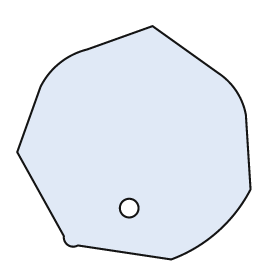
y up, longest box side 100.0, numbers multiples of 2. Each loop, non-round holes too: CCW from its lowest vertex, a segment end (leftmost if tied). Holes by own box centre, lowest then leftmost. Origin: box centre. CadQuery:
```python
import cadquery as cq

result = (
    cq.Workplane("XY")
    .moveTo(16.0, -50.0)
    .threePointArc((36.0, -38.0), (50.0, -20.0))
    .lineTo(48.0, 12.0)
    .threePointArc((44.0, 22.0), (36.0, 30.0))
    .lineTo(8.0, 50.0)
    .lineTo(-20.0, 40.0)
    .threePointArc((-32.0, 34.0), (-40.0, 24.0))
    .lineTo(-50.0, -4.0)
    .lineTo(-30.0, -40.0)
    .threePointArc((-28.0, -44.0), (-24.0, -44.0))
    .close()
    .moveTo(-2.0, -28.0)
    .circle(4.0)
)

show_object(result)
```